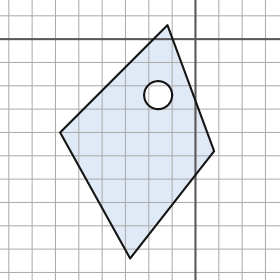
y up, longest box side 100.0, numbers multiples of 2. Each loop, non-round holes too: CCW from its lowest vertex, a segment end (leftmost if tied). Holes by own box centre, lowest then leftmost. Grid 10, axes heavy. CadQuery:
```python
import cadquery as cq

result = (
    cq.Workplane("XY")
    .moveTo(-28.0, -94.0)
    .lineTo(8.0, -48.0)
    .lineTo(-12.0, 6.0)
    .lineTo(-58.0, -40.0)
    .close()
    .moveTo(-16.0, -24.0)
    .circle(6.0)
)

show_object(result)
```